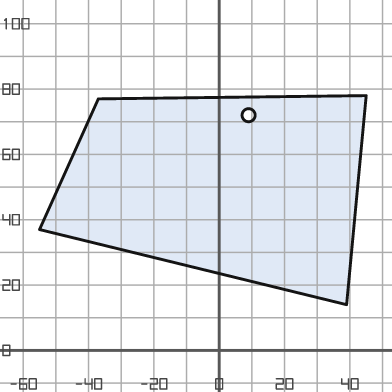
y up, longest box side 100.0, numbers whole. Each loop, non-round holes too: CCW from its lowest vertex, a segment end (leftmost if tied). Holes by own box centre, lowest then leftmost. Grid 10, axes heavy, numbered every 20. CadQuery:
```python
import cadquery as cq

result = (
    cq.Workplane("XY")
    .moveTo(39.0, 14.0)
    .lineTo(45.0, 78.0)
    .lineTo(-37.0, 77.0)
    .lineTo(-55.0, 37.0)
    .close()
    .moveTo(9.0, 72.0)
    .circle(2.0)
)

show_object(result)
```